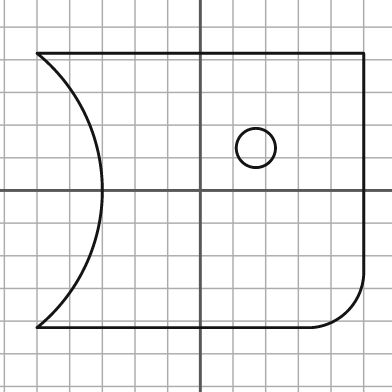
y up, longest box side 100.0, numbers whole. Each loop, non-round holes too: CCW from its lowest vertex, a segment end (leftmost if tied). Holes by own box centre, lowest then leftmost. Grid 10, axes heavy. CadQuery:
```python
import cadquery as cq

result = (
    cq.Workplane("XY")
    .moveTo(-50.0, -42.0)
    .lineTo(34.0, -42.0)
    .threePointArc((45.0, -37.0), (50.0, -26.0))
    .lineTo(50.0, 42.0)
    .lineTo(-50.0, 42.0)
    .threePointArc((-30.0, 0.0), (-50.0, -42.0))
    .close()
    .moveTo(17.0, 13.0)
    .circle(6.0)
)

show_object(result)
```